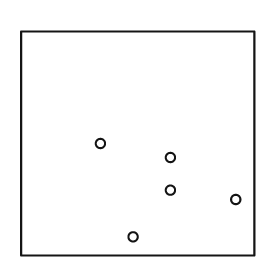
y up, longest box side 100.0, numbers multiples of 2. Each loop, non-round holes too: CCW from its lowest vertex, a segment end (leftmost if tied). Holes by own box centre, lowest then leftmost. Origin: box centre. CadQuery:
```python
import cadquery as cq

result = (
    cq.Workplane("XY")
    .moveTo(-50.0, -48.0)
    .lineTo(50.0, -48.0)
    .lineTo(50.0, 48.0)
    .lineTo(-50.0, 48.0)
    .close()
    .moveTo(-2.0, -40.0)
    .circle(2.0)
    .moveTo(42.0, -24.0)
    .circle(2.0)
    .moveTo(14.0, -20.0)
    .circle(2.0)
    .moveTo(14.0, -6.0)
    .circle(2.0)
    .moveTo(-16.0, 0.0)
    .circle(2.0)
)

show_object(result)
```